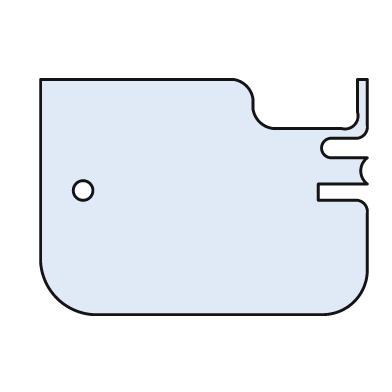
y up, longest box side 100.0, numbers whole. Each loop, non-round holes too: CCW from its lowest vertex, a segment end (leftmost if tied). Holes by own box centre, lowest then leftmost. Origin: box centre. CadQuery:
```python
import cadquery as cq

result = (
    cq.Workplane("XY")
    .moveTo(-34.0, -36.0)
    .lineTo(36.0, -36.0)
    .threePointArc((46.0, -32.0), (50.0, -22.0))
    .lineTo(50.0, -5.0)
    .threePointArc((49.0, -2.0), (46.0, -1.0))
    .lineTo(35.0, -1.0)
    .lineTo(35.0, 4.0)
    .lineTo(50.0, 4.0)
    .threePointArc((48.0, 8.0), (50.0, 12.0))
    .lineTo(39.0, 12.0)
    .threePointArc((36.0, 15.0), (39.0, 18.0))
    .lineTo(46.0, 18.0)
    .threePointArc((49.0, 19.0), (50.0, 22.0))
    .lineTo(50.0, 36.0)
    .lineTo(47.0, 36.0)
    .lineTo(47.0, 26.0)
    .threePointArc((46.0, 22.0), (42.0, 21.0))
    .lineTo(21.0, 21.0)
    .threePointArc((17.0, 23.0), (15.0, 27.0))
    .lineTo(15.0, 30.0)
    .threePointArc((13.0, 34.0), (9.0, 36.0))
    .lineTo(-50.0, 36.0)
    .lineTo(-50.0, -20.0)
    .threePointArc((-45.0, -31.0), (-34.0, -36.0))
    .close()
    .moveTo(-37.0, 2.0)
    .circle(3.0)
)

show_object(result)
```